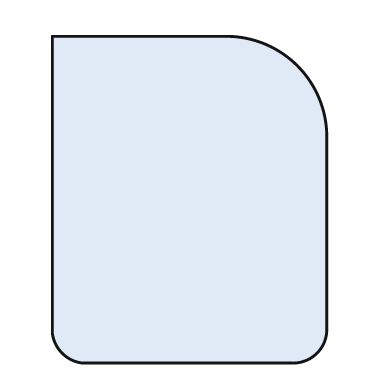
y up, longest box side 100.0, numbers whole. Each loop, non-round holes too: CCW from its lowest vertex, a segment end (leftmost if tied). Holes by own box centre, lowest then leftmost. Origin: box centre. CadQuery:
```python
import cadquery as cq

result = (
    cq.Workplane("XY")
    .moveTo(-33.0, -50.0)
    .lineTo(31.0, -50.0)
    .threePointArc((39.0, -47.0), (42.0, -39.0))
    .lineTo(42.0, 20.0)
    .threePointArc((33.0, 41.0), (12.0, 50.0))
    .lineTo(-42.0, 50.0)
    .lineTo(-42.0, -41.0)
    .threePointArc((-39.0, -47.0), (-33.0, -50.0))
    .close()
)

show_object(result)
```